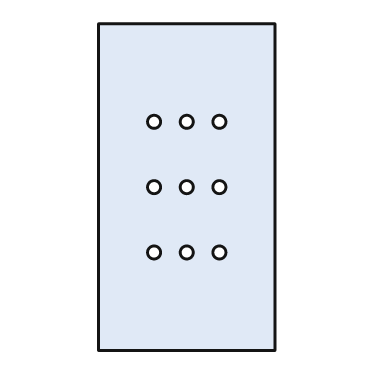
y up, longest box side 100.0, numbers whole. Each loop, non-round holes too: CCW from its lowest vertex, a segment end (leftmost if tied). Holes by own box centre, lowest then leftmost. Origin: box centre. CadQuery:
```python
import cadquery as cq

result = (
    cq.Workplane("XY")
    .moveTo(-27.0, -50.0)
    .lineTo(27.0, -50.0)
    .lineTo(27.0, 50.0)
    .lineTo(-27.0, 50.0)
    .close()
    .moveTo(-10.0, -20.0)
    .circle(2.0)
    .moveTo(0.0, -20.0)
    .circle(2.0)
    .moveTo(10.0, -20.0)
    .circle(2.0)
    .moveTo(-10.0, 0.0)
    .circle(2.0)
    .moveTo(0.0, 0.0)
    .circle(2.0)
    .moveTo(10.0, 0.0)
    .circle(2.0)
    .moveTo(-10.0, 20.0)
    .circle(2.0)
    .moveTo(0.0, 20.0)
    .circle(2.0)
    .moveTo(10.0, 20.0)
    .circle(2.0)
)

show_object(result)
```